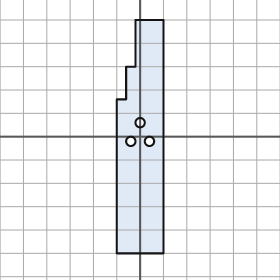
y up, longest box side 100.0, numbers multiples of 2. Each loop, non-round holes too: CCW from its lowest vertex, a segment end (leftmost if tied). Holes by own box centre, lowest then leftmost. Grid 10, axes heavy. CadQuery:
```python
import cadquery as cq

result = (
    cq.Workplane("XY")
    .moveTo(-10.0, -50.0)
    .lineTo(10.0, -50.0)
    .lineTo(10.0, 50.0)
    .lineTo(-2.0, 50.0)
    .lineTo(-2.0, 30.0)
    .lineTo(-6.0, 30.0)
    .lineTo(-6.0, 16.0)
    .lineTo(-10.0, 16.0)
    .close()
    .moveTo(-4.0, -2.0)
    .circle(2.0)
    .moveTo(4.0, -2.0)
    .circle(2.0)
    .moveTo(0.0, 6.0)
    .circle(2.0)
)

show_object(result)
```